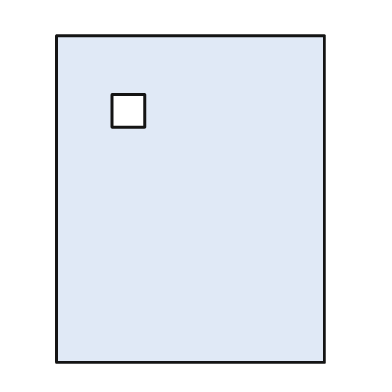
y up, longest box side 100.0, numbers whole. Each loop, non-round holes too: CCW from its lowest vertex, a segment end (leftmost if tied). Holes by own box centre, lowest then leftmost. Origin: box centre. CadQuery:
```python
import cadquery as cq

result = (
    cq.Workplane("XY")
    .moveTo(-41.0, -50.0)
    .lineTo(41.0, -50.0)
    .lineTo(41.0, 50.0)
    .lineTo(-41.0, 50.0)
    .close()
    .moveTo(-24.0, 22.0)
    .lineTo(-14.0, 22.0)
    .lineTo(-14.0, 32.0)
    .lineTo(-24.0, 32.0)
    .close()
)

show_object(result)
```